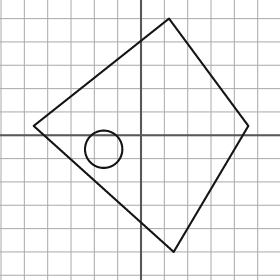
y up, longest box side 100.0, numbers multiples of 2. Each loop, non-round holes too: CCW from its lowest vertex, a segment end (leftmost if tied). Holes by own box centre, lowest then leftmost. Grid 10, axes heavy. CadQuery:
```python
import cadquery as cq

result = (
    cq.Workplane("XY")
    .moveTo(14.0, -50.0)
    .lineTo(46.0, 4.0)
    .lineTo(12.0, 50.0)
    .lineTo(-46.0, 4.0)
    .close()
    .moveTo(-16.0, -6.0)
    .circle(8.0)
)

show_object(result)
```